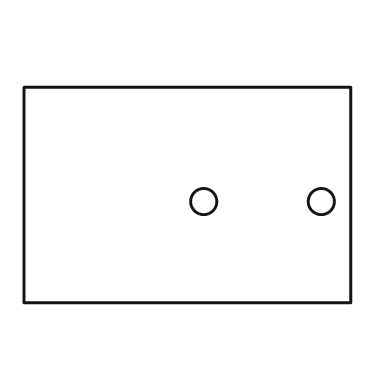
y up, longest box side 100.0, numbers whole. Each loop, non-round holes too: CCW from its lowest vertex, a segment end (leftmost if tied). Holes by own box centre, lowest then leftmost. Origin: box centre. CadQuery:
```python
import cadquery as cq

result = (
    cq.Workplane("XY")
    .moveTo(-50.0, -33.0)
    .lineTo(50.0, -33.0)
    .lineTo(50.0, 33.0)
    .lineTo(-50.0, 33.0)
    .close()
    .moveTo(5.0, -2.0)
    .circle(4.0)
    .moveTo(41.0, -2.0)
    .circle(4.0)
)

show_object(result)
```